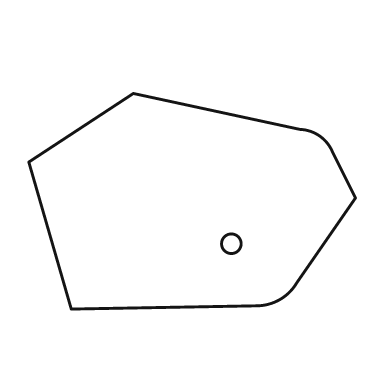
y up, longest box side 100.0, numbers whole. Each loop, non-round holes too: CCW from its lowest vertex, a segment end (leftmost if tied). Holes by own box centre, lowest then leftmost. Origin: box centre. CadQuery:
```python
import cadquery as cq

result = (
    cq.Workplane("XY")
    .moveTo(-37.0, -33.0)
    .lineTo(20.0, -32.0)
    .threePointArc((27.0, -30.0), (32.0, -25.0))
    .lineTo(50.0, 1.0)
    .lineTo(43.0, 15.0)
    .threePointArc((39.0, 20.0), (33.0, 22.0))
    .lineTo(-18.0, 33.0)
    .lineTo(-50.0, 12.0)
    .close()
    .moveTo(12.0, -13.0)
    .circle(3.0)
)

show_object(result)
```